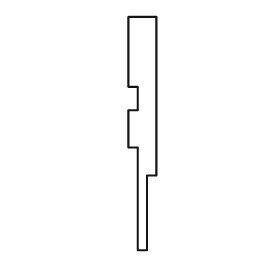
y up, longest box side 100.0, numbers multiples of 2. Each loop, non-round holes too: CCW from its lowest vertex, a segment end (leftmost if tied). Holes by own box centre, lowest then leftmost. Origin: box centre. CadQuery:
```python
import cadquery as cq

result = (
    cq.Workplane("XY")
    .moveTo(-2.0, -50.0)
    .lineTo(2.0, -50.0)
    .lineTo(2.0, -18.0)
    .lineTo(6.0, -18.0)
    .lineTo(6.0, 50.0)
    .lineTo(-6.0, 50.0)
    .lineTo(-6.0, 20.0)
    .lineTo(-2.0, 20.0)
    .lineTo(-2.0, 10.0)
    .lineTo(-6.0, 10.0)
    .lineTo(-6.0, -6.0)
    .lineTo(-2.0, -6.0)
    .close()
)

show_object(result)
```